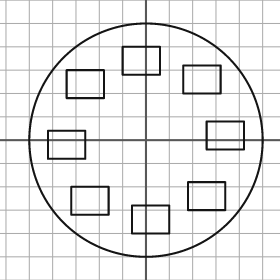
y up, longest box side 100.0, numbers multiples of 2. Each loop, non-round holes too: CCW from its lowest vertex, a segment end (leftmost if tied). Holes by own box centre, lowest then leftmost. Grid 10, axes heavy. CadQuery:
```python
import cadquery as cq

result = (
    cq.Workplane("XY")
    .moveTo(0.0, 0.0)
    .circle(50.0)
    .moveTo(-6.0, -40.0)
    .lineTo(10.0, -40.0)
    .lineTo(10.0, -28.0)
    .lineTo(-6.0, -28.0)
    .close()
    .moveTo(-32.0, -32.0)
    .lineTo(-16.0, -32.0)
    .lineTo(-16.0, -20.0)
    .lineTo(-32.0, -20.0)
    .close()
    .moveTo(18.0, -30.0)
    .lineTo(34.0, -30.0)
    .lineTo(34.0, -18.0)
    .lineTo(18.0, -18.0)
    .close()
    .moveTo(-42.0, -8.0)
    .lineTo(-26.0, -8.0)
    .lineTo(-26.0, 4.0)
    .lineTo(-42.0, 4.0)
    .close()
    .moveTo(26.0, -4.0)
    .lineTo(42.0, -4.0)
    .lineTo(42.0, 8.0)
    .lineTo(26.0, 8.0)
    .close()
    .moveTo(-34.0, 18.0)
    .lineTo(-18.0, 18.0)
    .lineTo(-18.0, 30.0)
    .lineTo(-34.0, 30.0)
    .close()
    .moveTo(16.0, 20.0)
    .lineTo(32.0, 20.0)
    .lineTo(32.0, 32.0)
    .lineTo(16.0, 32.0)
    .close()
    .moveTo(-10.0, 28.0)
    .lineTo(6.0, 28.0)
    .lineTo(6.0, 40.0)
    .lineTo(-10.0, 40.0)
    .close()
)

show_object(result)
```